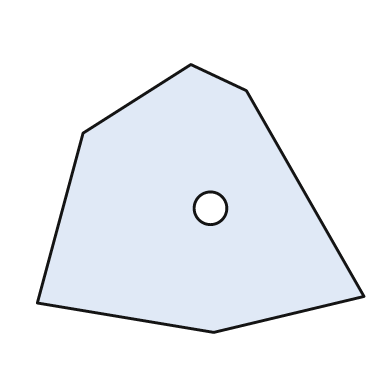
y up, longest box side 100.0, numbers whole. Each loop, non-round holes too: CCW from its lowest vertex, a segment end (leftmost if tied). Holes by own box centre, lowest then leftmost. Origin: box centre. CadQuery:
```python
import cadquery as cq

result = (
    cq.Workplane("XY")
    .moveTo(4.0, -41.0)
    .lineTo(50.0, -30.0)
    .lineTo(14.0, 33.0)
    .lineTo(-3.0, 41.0)
    .lineTo(-36.0, 20.0)
    .lineTo(-50.0, -32.0)
    .close()
    .moveTo(3.0, -3.0)
    .circle(5.0)
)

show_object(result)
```